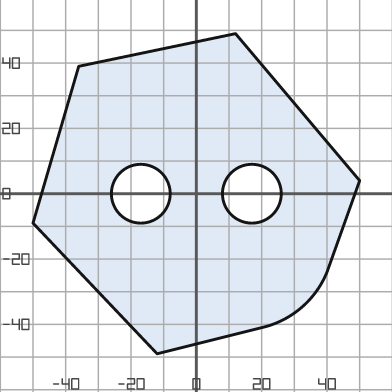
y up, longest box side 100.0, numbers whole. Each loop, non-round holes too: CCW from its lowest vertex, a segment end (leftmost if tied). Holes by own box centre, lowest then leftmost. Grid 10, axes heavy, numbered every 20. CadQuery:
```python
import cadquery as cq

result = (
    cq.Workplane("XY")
    .moveTo(-12.0, -49.0)
    .lineTo(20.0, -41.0)
    .threePointArc((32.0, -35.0), (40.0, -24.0))
    .lineTo(50.0, 4.0)
    .lineTo(12.0, 49.0)
    .lineTo(-36.0, 39.0)
    .lineTo(-50.0, -9.0)
    .close()
    .moveTo(-17.0, 0.0)
    .circle(9.0)
    .moveTo(17.0, 0.0)
    .circle(9.0)
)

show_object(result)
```